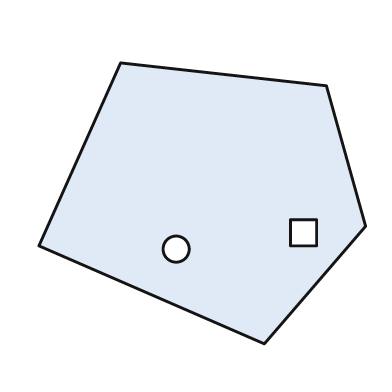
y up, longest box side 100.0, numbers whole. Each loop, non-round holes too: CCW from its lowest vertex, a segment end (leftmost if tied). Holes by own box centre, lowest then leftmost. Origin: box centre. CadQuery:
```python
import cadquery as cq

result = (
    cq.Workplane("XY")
    .moveTo(19.0, -43.0)
    .lineTo(50.0, -7.0)
    .lineTo(38.0, 36.0)
    .lineTo(-25.0, 43.0)
    .lineTo(-50.0, -13.0)
    .close()
    .moveTo(-8.0, -14.0)
    .circle(4.0)
    .moveTo(27.0, -13.0)
    .lineTo(35.0, -13.0)
    .lineTo(35.0, -5.0)
    .lineTo(27.0, -5.0)
    .close()
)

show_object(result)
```